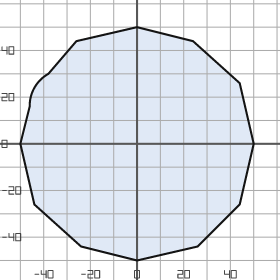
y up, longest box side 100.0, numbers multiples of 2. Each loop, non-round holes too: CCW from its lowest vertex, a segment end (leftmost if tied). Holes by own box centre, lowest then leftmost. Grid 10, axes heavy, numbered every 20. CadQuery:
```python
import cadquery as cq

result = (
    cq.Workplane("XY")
    .moveTo(0.0, -50.0)
    .lineTo(26.0, -44.0)
    .lineTo(44.0, -26.0)
    .lineTo(50.0, 0.0)
    .lineTo(44.0, 26.0)
    .lineTo(24.0, 44.0)
    .lineTo(0.0, 50.0)
    .lineTo(-26.0, 44.0)
    .lineTo(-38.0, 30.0)
    .threePointArc((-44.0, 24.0), (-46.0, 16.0))
    .lineTo(-50.0, 0.0)
    .lineTo(-44.0, -26.0)
    .lineTo(-24.0, -44.0)
    .close()
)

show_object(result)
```